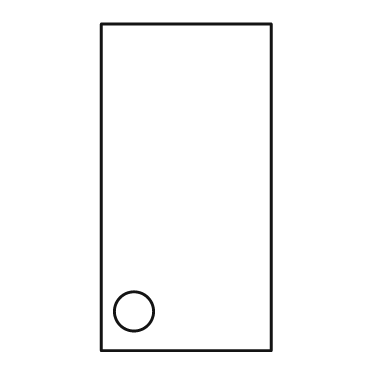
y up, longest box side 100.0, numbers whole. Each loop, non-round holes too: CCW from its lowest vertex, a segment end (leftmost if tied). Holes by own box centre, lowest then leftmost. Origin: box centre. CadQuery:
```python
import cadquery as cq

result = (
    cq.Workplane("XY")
    .moveTo(-26.0, -50.0)
    .lineTo(26.0, -50.0)
    .lineTo(26.0, 50.0)
    .lineTo(-26.0, 50.0)
    .close()
    .moveTo(-16.0, -38.0)
    .circle(6.0)
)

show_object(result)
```